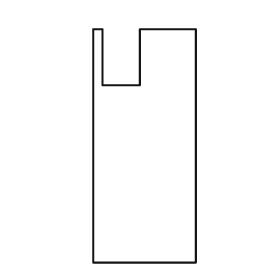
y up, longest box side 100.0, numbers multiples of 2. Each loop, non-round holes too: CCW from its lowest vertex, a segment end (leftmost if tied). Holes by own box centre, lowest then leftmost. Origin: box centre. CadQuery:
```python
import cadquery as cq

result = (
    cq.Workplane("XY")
    .moveTo(-22.0, -50.0)
    .lineTo(22.0, -50.0)
    .lineTo(22.0, 50.0)
    .lineTo(-2.0, 50.0)
    .lineTo(-2.0, 26.0)
    .lineTo(-18.0, 26.0)
    .lineTo(-18.0, 50.0)
    .lineTo(-22.0, 50.0)
    .close()
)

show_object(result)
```